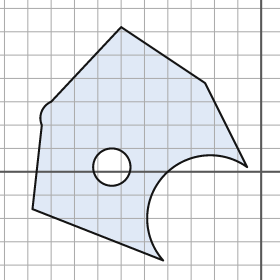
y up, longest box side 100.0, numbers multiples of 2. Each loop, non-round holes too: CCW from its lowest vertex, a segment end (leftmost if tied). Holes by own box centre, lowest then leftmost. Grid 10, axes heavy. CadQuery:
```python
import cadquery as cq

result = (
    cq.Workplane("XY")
    .moveTo(-42.0, -38.0)
    .threePointArc((-42.0, -2.0), (-6.0, 2.0))
    .lineTo(-24.0, 38.0)
    .lineTo(-60.0, 62.0)
    .lineTo(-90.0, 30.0)
    .threePointArc((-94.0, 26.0), (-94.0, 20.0))
    .lineTo(-98.0, -16.0)
    .close()
    .moveTo(-64.0, 2.0)
    .circle(8.0)
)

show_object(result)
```